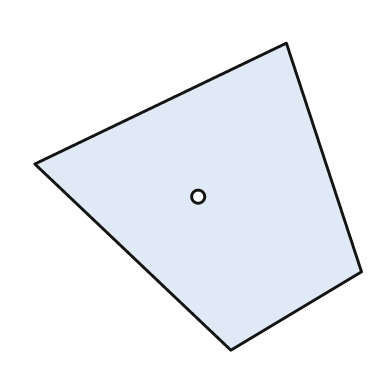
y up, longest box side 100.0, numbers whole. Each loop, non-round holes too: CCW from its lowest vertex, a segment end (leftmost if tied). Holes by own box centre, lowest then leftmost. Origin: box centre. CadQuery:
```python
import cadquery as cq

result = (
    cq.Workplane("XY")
    .moveTo(10.0, -47.0)
    .lineTo(50.0, -23.0)
    .lineTo(27.0, 47.0)
    .lineTo(-50.0, 10.0)
    .close()
    .moveTo(0.0, 0.0)
    .circle(2.0)
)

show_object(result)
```